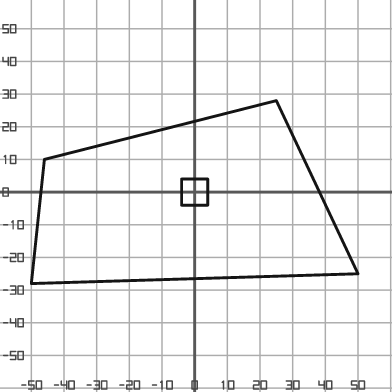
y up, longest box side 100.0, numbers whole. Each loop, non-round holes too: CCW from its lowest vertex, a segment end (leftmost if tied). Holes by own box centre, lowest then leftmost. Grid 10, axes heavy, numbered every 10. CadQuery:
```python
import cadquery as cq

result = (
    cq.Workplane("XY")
    .moveTo(-50.0, -28.0)
    .lineTo(50.0, -25.0)
    .lineTo(25.0, 28.0)
    .lineTo(-46.0, 10.0)
    .close()
    .moveTo(-4.0, -4.0)
    .lineTo(4.0, -4.0)
    .lineTo(4.0, 4.0)
    .lineTo(-4.0, 4.0)
    .close()
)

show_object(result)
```